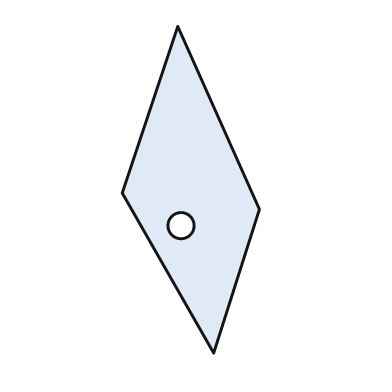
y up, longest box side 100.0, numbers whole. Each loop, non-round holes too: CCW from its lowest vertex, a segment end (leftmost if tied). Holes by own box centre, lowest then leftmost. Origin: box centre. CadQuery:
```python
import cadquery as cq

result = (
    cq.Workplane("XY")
    .moveTo(7.0, -50.0)
    .lineTo(21.0, -6.0)
    .lineTo(-4.0, 50.0)
    .lineTo(-21.0, -1.0)
    .close()
    .moveTo(-3.0, -11.0)
    .circle(4.0)
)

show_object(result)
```